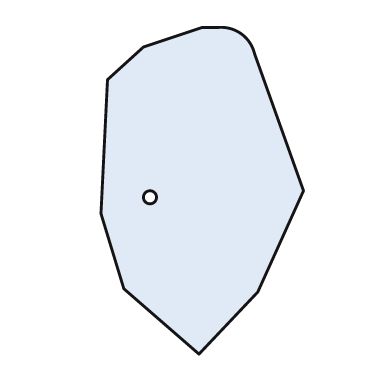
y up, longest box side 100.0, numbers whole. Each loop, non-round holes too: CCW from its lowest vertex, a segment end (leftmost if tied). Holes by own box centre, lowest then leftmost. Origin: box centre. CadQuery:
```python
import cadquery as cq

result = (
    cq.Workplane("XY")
    .moveTo(-1.0, -50.0)
    .lineTo(17.0, -31.0)
    .lineTo(31.0, 0.0)
    .lineTo(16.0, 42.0)
    .threePointArc((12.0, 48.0), (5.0, 50.0))
    .lineTo(0.0, 50.0)
    .lineTo(-18.0, 44.0)
    .lineTo(-29.0, 34.0)
    .lineTo(-31.0, -7.0)
    .lineTo(-24.0, -30.0)
    .close()
    .moveTo(-16.0, -2.0)
    .circle(2.0)
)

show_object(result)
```